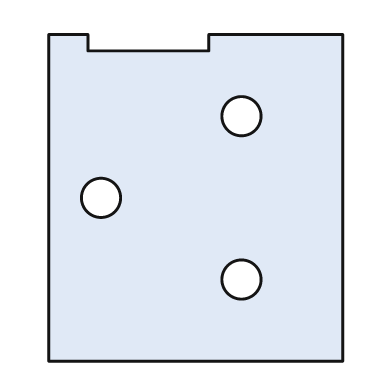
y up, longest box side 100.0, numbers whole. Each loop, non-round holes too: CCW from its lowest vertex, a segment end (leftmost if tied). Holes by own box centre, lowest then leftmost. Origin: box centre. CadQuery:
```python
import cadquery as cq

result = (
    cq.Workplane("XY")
    .moveTo(-45.0, -50.0)
    .lineTo(45.0, -50.0)
    .lineTo(45.0, 50.0)
    .lineTo(4.0, 50.0)
    .lineTo(4.0, 45.0)
    .lineTo(-33.0, 45.0)
    .lineTo(-33.0, 50.0)
    .lineTo(-45.0, 50.0)
    .close()
    .moveTo(14.0, -25.0)
    .circle(6.0)
    .moveTo(-29.0, 0.0)
    .circle(6.0)
    .moveTo(14.0, 25.0)
    .circle(6.0)
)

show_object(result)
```